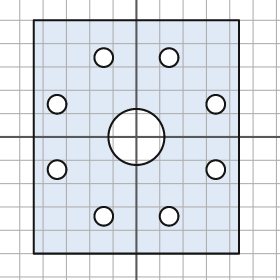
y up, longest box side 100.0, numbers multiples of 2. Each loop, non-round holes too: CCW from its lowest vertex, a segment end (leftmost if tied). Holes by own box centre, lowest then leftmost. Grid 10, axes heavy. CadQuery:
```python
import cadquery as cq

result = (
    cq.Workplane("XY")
    .moveTo(-44.0, -50.0)
    .lineTo(44.0, -50.0)
    .lineTo(44.0, 50.0)
    .lineTo(-44.0, 50.0)
    .close()
    .moveTo(-14.0, -34.0)
    .circle(4.0)
    .moveTo(14.0, -34.0)
    .circle(4.0)
    .moveTo(-34.0, -14.0)
    .circle(4.0)
    .moveTo(34.0, -14.0)
    .circle(4.0)
    .moveTo(0.0, 0.0)
    .circle(12.0)
    .moveTo(-34.0, 14.0)
    .circle(4.0)
    .moveTo(34.0, 14.0)
    .circle(4.0)
    .moveTo(-14.0, 34.0)
    .circle(4.0)
    .moveTo(14.0, 34.0)
    .circle(4.0)
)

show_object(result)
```